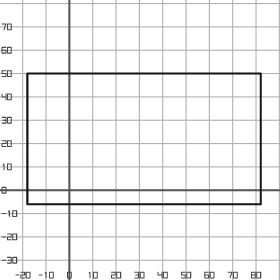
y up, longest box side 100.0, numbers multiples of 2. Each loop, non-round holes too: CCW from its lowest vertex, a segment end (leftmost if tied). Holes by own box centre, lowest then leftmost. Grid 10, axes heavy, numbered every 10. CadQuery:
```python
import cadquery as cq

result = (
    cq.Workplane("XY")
    .moveTo(-18.0, -6.0)
    .lineTo(82.0, -6.0)
    .lineTo(82.0, 50.0)
    .lineTo(-18.0, 50.0)
    .close()
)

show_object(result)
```